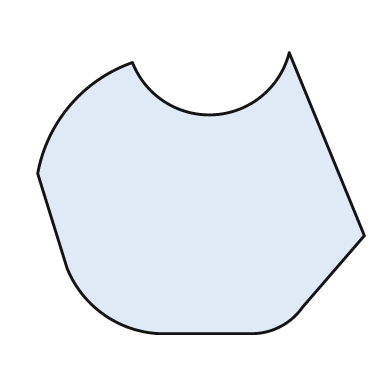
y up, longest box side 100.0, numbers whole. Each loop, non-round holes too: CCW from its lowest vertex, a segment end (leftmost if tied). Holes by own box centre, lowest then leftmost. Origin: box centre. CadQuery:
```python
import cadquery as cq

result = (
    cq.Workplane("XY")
    .moveTo(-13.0, -43.0)
    .lineTo(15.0, -43.0)
    .threePointArc((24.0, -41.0), (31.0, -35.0))
    .lineTo(50.0, -13.0)
    .lineTo(27.0, 43.0)
    .threePointArc((4.0, 24.0), (-21.0, 40.0))
    .threePointArc((-40.0, 27.0), (-50.0, 6.0))
    .lineTo(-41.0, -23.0)
    .threePointArc((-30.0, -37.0), (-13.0, -43.0))
    .close()
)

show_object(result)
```